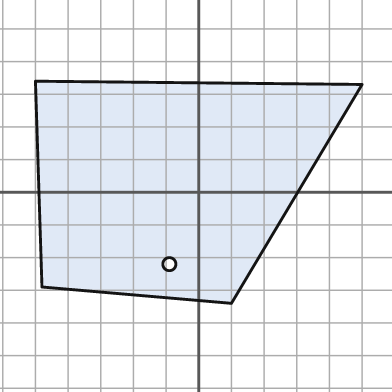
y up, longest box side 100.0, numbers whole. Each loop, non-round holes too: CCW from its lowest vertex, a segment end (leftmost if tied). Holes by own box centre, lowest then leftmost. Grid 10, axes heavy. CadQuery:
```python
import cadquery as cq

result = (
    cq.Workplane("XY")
    .moveTo(10.0, -34.0)
    .lineTo(50.0, 33.0)
    .lineTo(-50.0, 34.0)
    .lineTo(-48.0, -29.0)
    .close()
    .moveTo(-9.0, -22.0)
    .circle(2.0)
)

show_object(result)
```